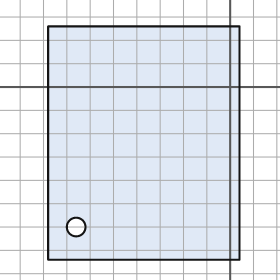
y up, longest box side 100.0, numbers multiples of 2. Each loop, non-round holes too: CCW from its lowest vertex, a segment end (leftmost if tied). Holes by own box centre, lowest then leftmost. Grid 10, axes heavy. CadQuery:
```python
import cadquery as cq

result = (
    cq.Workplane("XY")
    .moveTo(-78.0, -74.0)
    .lineTo(4.0, -74.0)
    .lineTo(4.0, 26.0)
    .lineTo(-78.0, 26.0)
    .close()
    .moveTo(-66.0, -60.0)
    .circle(4.0)
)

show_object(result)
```